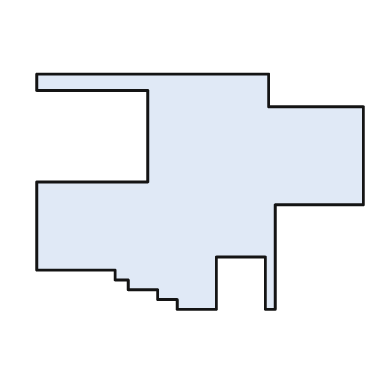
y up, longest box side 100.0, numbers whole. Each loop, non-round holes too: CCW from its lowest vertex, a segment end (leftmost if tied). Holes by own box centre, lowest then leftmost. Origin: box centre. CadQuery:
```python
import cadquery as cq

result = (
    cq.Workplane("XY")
    .moveTo(-7.0, -36.0)
    .lineTo(5.0, -36.0)
    .lineTo(5.0, -20.0)
    .lineTo(20.0, -20.0)
    .lineTo(20.0, -36.0)
    .lineTo(23.0, -36.0)
    .lineTo(23.0, -4.0)
    .lineTo(50.0, -4.0)
    .lineTo(50.0, 26.0)
    .lineTo(21.0, 26.0)
    .lineTo(21.0, 36.0)
    .lineTo(-50.0, 36.0)
    .lineTo(-50.0, 31.0)
    .lineTo(-16.0, 31.0)
    .lineTo(-16.0, 3.0)
    .lineTo(-50.0, 3.0)
    .lineTo(-50.0, -24.0)
    .lineTo(-26.0, -24.0)
    .lineTo(-26.0, -27.0)
    .lineTo(-22.0, -27.0)
    .lineTo(-22.0, -30.0)
    .lineTo(-13.0, -30.0)
    .lineTo(-13.0, -33.0)
    .lineTo(-7.0, -33.0)
    .close()
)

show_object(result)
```